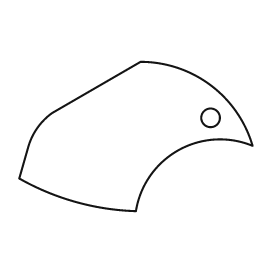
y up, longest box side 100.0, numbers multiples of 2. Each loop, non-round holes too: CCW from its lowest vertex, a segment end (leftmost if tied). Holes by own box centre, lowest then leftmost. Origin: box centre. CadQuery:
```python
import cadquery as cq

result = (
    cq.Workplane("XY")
    .moveTo(0.0, -32.0)
    .threePointArc((18.0, -6.0), (50.0, -4.0))
    .threePointArc((32.0, 22.0), (2.0, 32.0))
    .lineTo(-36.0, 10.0)
    .threePointArc((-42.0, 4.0), (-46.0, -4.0))
    .lineTo(-50.0, -18.0)
    .threePointArc((-26.0, -28.0), (0.0, -32.0))
    .close()
    .moveTo(32.0, 8.0)
    .circle(4.0)
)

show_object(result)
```